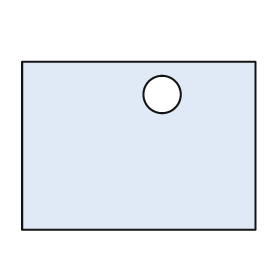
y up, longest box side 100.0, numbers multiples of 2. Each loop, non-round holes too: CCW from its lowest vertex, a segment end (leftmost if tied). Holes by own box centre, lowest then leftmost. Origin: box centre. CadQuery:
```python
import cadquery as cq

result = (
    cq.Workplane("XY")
    .moveTo(-50.0, -36.0)
    .lineTo(50.0, -36.0)
    .lineTo(50.0, 36.0)
    .lineTo(-50.0, 36.0)
    .close()
    .moveTo(10.0, 22.0)
    .circle(8.0)
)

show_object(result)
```